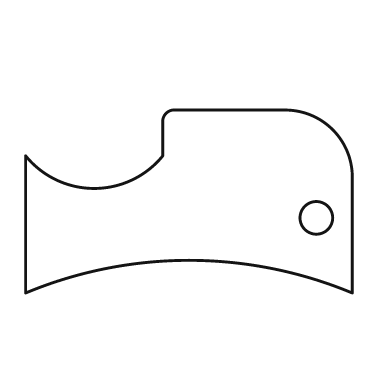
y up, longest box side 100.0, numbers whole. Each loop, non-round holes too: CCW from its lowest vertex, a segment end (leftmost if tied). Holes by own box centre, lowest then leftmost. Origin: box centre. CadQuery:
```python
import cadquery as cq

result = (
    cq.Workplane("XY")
    .moveTo(-50.0, -28.0)
    .threePointArc((0.0, -18.0), (50.0, -28.0))
    .lineTo(50.0, 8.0)
    .threePointArc((44.0, 22.0), (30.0, 28.0))
    .lineTo(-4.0, 28.0)
    .threePointArc((-7.0, 27.0), (-8.0, 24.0))
    .lineTo(-8.0, 14.0)
    .threePointArc((-29.0, 4.0), (-50.0, 14.0))
    .close()
    .moveTo(39.0, -5.0)
    .circle(5.0)
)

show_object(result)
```